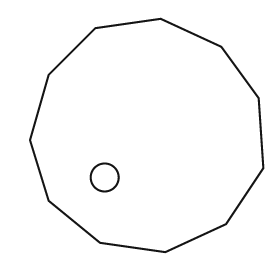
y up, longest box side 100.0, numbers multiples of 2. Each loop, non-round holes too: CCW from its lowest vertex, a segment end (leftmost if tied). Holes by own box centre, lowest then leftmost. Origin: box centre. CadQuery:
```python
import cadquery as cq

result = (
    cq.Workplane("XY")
    .moveTo(8.0, -50.0)
    .lineTo(34.0, -38.0)
    .lineTo(50.0, -14.0)
    .lineTo(48.0, 16.0)
    .lineTo(32.0, 38.0)
    .lineTo(6.0, 50.0)
    .lineTo(-22.0, 46.0)
    .lineTo(-42.0, 26.0)
    .lineTo(-50.0, -2.0)
    .lineTo(-42.0, -28.0)
    .lineTo(-20.0, -46.0)
    .close()
    .moveTo(-18.0, -18.0)
    .circle(6.0)
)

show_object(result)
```